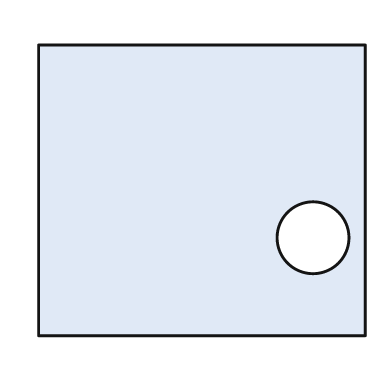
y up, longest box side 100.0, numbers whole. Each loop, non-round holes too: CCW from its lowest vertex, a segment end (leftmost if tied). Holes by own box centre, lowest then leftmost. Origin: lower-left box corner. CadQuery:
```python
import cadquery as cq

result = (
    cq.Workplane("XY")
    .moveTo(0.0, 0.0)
    .lineTo(100.0, 0.0)
    .lineTo(100.0, 89.0)
    .lineTo(0.0, 89.0)
    .close()
    .moveTo(84.0, 30.0)
    .circle(11.0)
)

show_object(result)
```